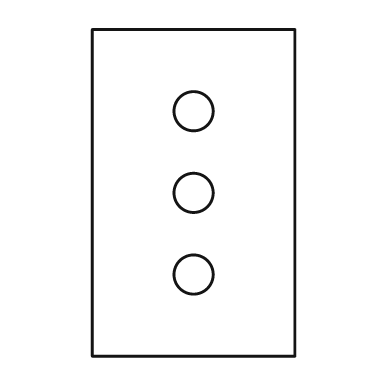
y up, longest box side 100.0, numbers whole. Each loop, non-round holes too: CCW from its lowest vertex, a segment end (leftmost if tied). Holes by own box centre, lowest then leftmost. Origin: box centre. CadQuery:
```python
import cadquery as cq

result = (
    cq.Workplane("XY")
    .moveTo(-31.0, -50.0)
    .lineTo(31.0, -50.0)
    .lineTo(31.0, 50.0)
    .lineTo(-31.0, 50.0)
    .close()
    .moveTo(0.0, -25.0)
    .circle(6.0)
    .moveTo(0.0, 0.0)
    .circle(6.0)
    .moveTo(0.0, 25.0)
    .circle(6.0)
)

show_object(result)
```